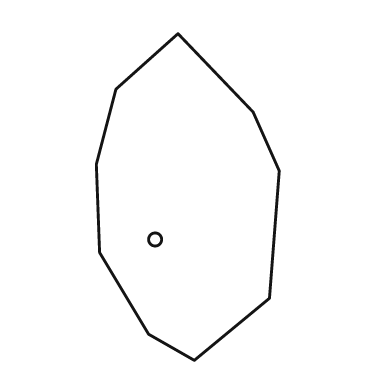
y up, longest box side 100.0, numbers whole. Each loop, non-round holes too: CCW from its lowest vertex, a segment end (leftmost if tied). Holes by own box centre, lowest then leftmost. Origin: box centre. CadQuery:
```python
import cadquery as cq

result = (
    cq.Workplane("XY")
    .moveTo(2.0, -50.0)
    .lineTo(25.0, -31.0)
    .lineTo(28.0, 8.0)
    .lineTo(20.0, 26.0)
    .lineTo(-3.0, 50.0)
    .lineTo(-22.0, 33.0)
    .lineTo(-28.0, 10.0)
    .lineTo(-27.0, -17.0)
    .lineTo(-12.0, -42.0)
    .close()
    .moveTo(-10.0, -13.0)
    .circle(2.0)
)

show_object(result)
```